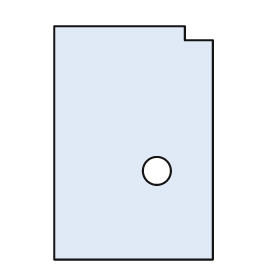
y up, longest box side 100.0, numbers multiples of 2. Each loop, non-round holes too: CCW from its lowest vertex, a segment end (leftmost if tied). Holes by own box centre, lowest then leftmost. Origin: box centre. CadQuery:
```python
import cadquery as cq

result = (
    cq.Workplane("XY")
    .moveTo(-34.0, -50.0)
    .lineTo(34.0, -50.0)
    .lineTo(34.0, 44.0)
    .lineTo(22.0, 44.0)
    .lineTo(22.0, 50.0)
    .lineTo(-34.0, 50.0)
    .close()
    .moveTo(10.0, -12.0)
    .circle(6.0)
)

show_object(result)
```